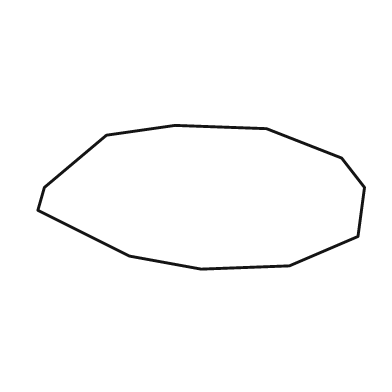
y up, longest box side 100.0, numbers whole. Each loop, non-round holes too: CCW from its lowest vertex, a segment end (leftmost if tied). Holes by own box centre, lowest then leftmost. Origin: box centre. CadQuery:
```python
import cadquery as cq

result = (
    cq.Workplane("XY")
    .moveTo(0.0, -22.0)
    .lineTo(27.0, -21.0)
    .lineTo(48.0, -12.0)
    .lineTo(50.0, 3.0)
    .lineTo(43.0, 12.0)
    .lineTo(20.0, 21.0)
    .lineTo(-8.0, 22.0)
    .lineTo(-29.0, 19.0)
    .lineTo(-48.0, 3.0)
    .lineTo(-50.0, -4.0)
    .lineTo(-22.0, -18.0)
    .close()
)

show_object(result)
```